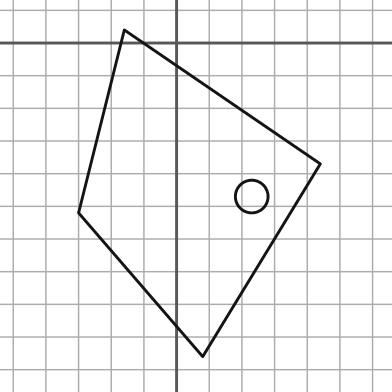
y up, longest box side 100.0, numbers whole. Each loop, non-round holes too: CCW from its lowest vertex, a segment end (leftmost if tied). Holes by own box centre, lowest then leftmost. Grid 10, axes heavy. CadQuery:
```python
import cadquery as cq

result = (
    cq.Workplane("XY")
    .moveTo(8.0, -96.0)
    .lineTo(44.0, -37.0)
    .lineTo(-16.0, 4.0)
    .lineTo(-30.0, -52.0)
    .close()
    .moveTo(23.0, -47.0)
    .circle(5.0)
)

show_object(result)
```